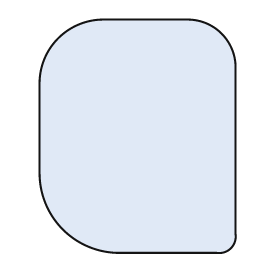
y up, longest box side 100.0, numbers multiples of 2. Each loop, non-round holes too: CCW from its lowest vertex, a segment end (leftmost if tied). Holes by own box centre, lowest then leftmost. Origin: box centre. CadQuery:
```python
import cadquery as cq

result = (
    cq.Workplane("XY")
    .moveTo(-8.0, -50.0)
    .lineTo(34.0, -50.0)
    .threePointArc((40.0, -48.0), (42.0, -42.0))
    .lineTo(42.0, 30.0)
    .threePointArc((36.0, 44.0), (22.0, 50.0))
    .lineTo(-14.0, 50.0)
    .threePointArc((-34.0, 42.0), (-42.0, 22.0))
    .lineTo(-42.0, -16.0)
    .threePointArc((-32.0, -40.0), (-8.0, -50.0))
    .close()
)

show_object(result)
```